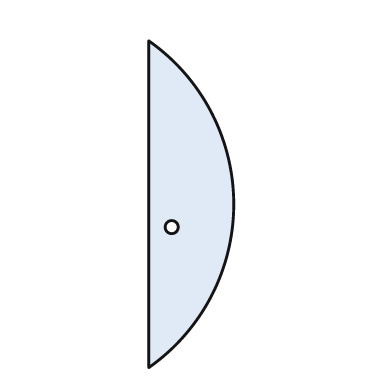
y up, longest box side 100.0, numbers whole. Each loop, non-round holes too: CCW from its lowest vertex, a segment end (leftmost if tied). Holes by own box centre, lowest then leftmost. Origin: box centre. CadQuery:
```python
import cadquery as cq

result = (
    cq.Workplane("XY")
    .moveTo(-13.0, -50.0)
    .threePointArc((13.0, 0.0), (-13.0, 50.0))
    .close()
    .moveTo(-6.0, -7.0)
    .circle(2.0)
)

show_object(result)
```